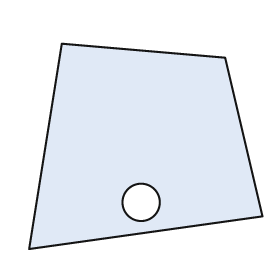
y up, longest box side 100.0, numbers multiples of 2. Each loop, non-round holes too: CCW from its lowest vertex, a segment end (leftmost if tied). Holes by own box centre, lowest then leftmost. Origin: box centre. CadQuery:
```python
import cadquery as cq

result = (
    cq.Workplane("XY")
    .moveTo(-50.0, -44.0)
    .lineTo(50.0, -30.0)
    .lineTo(34.0, 38.0)
    .lineTo(-36.0, 44.0)
    .close()
    .moveTo(-2.0, -24.0)
    .circle(8.0)
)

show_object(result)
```